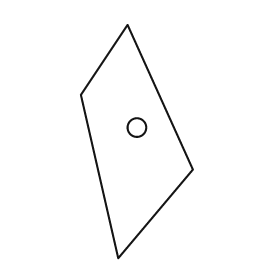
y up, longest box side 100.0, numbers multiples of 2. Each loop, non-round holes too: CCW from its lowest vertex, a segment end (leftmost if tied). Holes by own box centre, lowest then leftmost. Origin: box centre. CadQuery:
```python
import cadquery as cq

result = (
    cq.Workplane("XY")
    .moveTo(-8.0, -50.0)
    .lineTo(24.0, -12.0)
    .lineTo(-4.0, 50.0)
    .lineTo(-24.0, 20.0)
    .close()
    .moveTo(0.0, 6.0)
    .circle(4.0)
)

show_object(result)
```